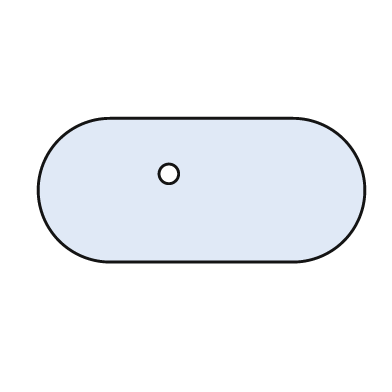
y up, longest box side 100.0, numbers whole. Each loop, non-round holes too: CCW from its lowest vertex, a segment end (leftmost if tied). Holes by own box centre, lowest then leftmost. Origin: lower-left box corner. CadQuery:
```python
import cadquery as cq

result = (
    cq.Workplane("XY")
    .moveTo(22.0, 0.0)
    .lineTo(78.0, 0.0)
    .threePointArc((100.0, 22.0), (78.0, 44.0))
    .lineTo(22.0, 44.0)
    .threePointArc((0.0, 22.0), (22.0, 0.0))
    .close()
    .moveTo(40.0, 27.0)
    .circle(3.0)
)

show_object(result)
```